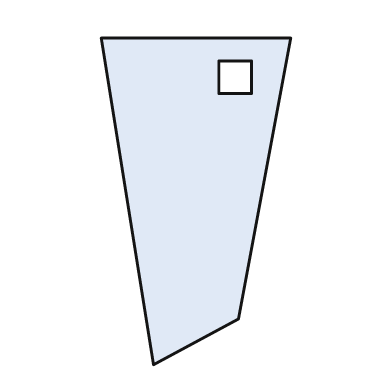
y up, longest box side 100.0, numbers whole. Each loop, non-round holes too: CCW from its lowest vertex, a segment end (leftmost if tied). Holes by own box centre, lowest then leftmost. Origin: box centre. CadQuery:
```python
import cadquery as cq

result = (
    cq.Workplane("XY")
    .moveTo(-13.0, -50.0)
    .lineTo(13.0, -36.0)
    .lineTo(29.0, 50.0)
    .lineTo(-29.0, 50.0)
    .close()
    .moveTo(7.0, 33.0)
    .lineTo(17.0, 33.0)
    .lineTo(17.0, 43.0)
    .lineTo(7.0, 43.0)
    .close()
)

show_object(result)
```